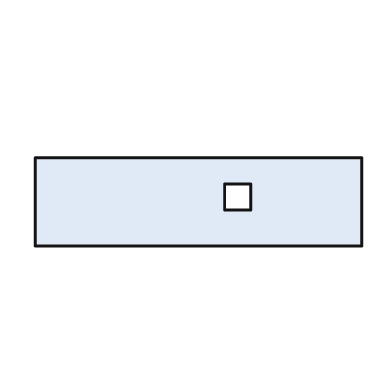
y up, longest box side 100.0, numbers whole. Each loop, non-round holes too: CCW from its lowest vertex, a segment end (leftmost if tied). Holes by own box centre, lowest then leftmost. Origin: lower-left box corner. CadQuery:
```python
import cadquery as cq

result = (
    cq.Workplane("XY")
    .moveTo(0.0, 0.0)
    .lineTo(100.0, 0.0)
    .lineTo(100.0, 27.0)
    .lineTo(0.0, 27.0)
    .close()
    .moveTo(58.0, 11.0)
    .lineTo(66.0, 11.0)
    .lineTo(66.0, 19.0)
    .lineTo(58.0, 19.0)
    .close()
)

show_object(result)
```